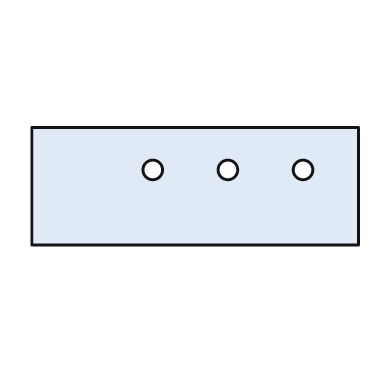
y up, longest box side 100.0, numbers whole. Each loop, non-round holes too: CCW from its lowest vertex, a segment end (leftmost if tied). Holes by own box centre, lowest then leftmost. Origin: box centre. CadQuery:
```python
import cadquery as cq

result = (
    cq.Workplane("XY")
    .moveTo(-50.0, -18.0)
    .lineTo(50.0, -18.0)
    .lineTo(50.0, 18.0)
    .lineTo(-50.0, 18.0)
    .close()
    .moveTo(-13.0, 5.0)
    .circle(3.0)
    .moveTo(10.0, 5.0)
    .circle(3.0)
    .moveTo(33.0, 5.0)
    .circle(3.0)
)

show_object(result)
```